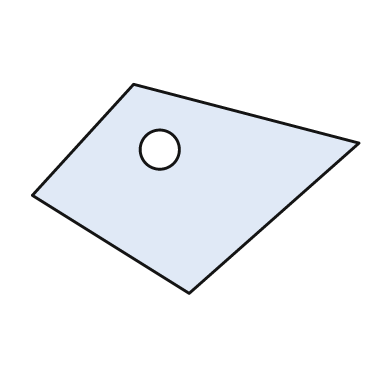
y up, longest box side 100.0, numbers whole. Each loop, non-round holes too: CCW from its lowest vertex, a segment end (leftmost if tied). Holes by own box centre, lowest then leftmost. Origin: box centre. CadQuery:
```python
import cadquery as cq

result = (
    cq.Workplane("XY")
    .moveTo(-2.0, -32.0)
    .lineTo(50.0, 14.0)
    .lineTo(-19.0, 32.0)
    .lineTo(-50.0, -2.0)
    .close()
    .moveTo(-11.0, 12.0)
    .circle(6.0)
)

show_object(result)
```